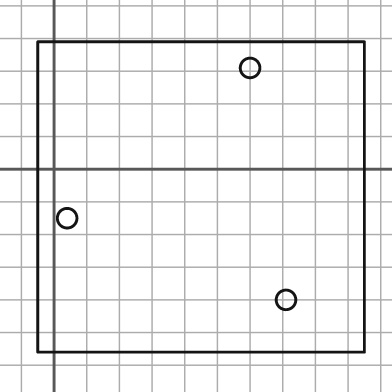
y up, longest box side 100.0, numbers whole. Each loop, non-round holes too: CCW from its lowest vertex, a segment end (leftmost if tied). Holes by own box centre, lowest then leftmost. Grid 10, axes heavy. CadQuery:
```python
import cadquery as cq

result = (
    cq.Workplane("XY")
    .moveTo(-5.0, -56.0)
    .lineTo(95.0, -56.0)
    .lineTo(95.0, 39.0)
    .lineTo(-5.0, 39.0)
    .close()
    .moveTo(71.0, -40.0)
    .circle(3.0)
    .moveTo(4.0, -15.0)
    .circle(3.0)
    .moveTo(60.0, 31.0)
    .circle(3.0)
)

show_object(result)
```